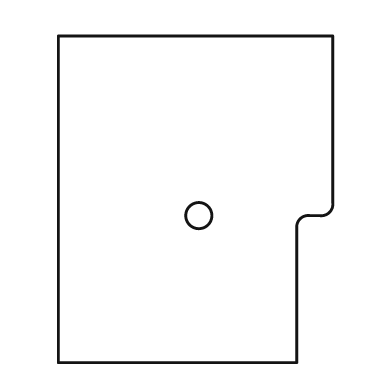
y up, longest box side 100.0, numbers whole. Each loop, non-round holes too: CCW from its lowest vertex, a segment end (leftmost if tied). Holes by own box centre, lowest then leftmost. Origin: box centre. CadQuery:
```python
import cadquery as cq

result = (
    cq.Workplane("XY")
    .moveTo(-42.0, -50.0)
    .lineTo(31.0, -50.0)
    .lineTo(31.0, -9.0)
    .threePointArc((32.0, -6.0), (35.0, -5.0))
    .lineTo(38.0, -5.0)
    .threePointArc((41.0, -4.0), (42.0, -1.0))
    .lineTo(42.0, 50.0)
    .lineTo(-42.0, 50.0)
    .close()
    .moveTo(1.0, -5.0)
    .circle(4.0)
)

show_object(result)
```